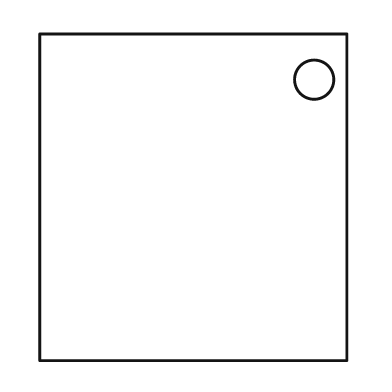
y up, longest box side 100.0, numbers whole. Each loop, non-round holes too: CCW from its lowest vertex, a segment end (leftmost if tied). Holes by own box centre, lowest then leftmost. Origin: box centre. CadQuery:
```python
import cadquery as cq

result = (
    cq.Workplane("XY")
    .moveTo(-47.0, -50.0)
    .lineTo(47.0, -50.0)
    .lineTo(47.0, 50.0)
    .lineTo(-47.0, 50.0)
    .close()
    .moveTo(37.0, 36.0)
    .circle(6.0)
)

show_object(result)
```